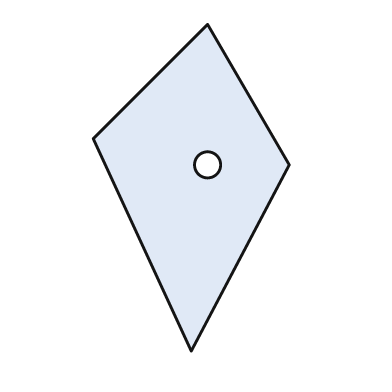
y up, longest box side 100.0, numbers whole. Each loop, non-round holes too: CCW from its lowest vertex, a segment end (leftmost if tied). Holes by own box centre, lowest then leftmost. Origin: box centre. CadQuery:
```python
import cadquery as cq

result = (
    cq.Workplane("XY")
    .moveTo(0.0, -50.0)
    .lineTo(30.0, 7.0)
    .lineTo(5.0, 50.0)
    .lineTo(-30.0, 15.0)
    .close()
    .moveTo(5.0, 7.0)
    .circle(4.0)
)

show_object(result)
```